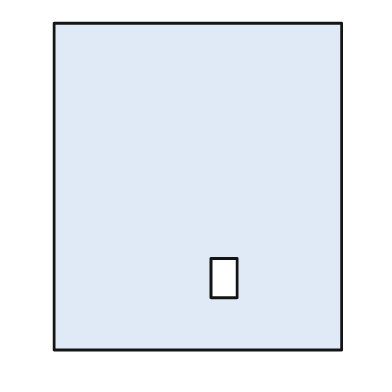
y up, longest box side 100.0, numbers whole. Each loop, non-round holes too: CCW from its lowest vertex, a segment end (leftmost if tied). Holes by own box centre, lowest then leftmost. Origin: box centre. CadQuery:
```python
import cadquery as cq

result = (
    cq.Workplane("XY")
    .moveTo(-44.0, -50.0)
    .lineTo(44.0, -50.0)
    .lineTo(44.0, 50.0)
    .lineTo(-44.0, 50.0)
    .close()
    .moveTo(4.0, -34.0)
    .lineTo(12.0, -34.0)
    .lineTo(12.0, -22.0)
    .lineTo(4.0, -22.0)
    .close()
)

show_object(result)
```